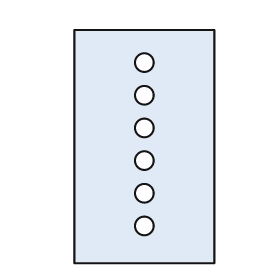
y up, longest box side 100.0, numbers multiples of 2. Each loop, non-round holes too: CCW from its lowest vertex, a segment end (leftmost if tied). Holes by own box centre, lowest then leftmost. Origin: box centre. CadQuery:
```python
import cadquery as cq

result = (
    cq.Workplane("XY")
    .moveTo(-30.0, -50.0)
    .lineTo(30.0, -50.0)
    .lineTo(30.0, 50.0)
    .lineTo(-30.0, 50.0)
    .close()
    .moveTo(0.0, -34.0)
    .circle(4.0)
    .moveTo(0.0, -20.0)
    .circle(4.0)
    .moveTo(0.0, -6.0)
    .circle(4.0)
    .moveTo(0.0, 8.0)
    .circle(4.0)
    .moveTo(0.0, 22.0)
    .circle(4.0)
    .moveTo(0.0, 36.0)
    .circle(4.0)
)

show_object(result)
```